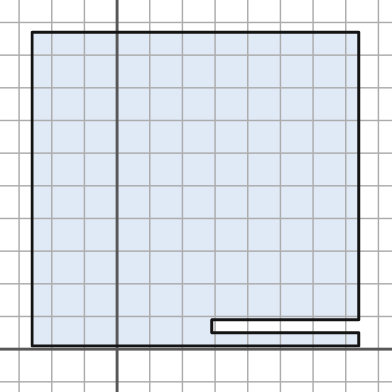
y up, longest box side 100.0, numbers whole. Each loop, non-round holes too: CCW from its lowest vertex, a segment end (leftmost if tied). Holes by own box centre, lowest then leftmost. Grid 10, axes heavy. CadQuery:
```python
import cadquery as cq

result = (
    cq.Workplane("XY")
    .moveTo(-26.0, 1.0)
    .lineTo(74.0, 1.0)
    .lineTo(74.0, 5.0)
    .lineTo(29.0, 5.0)
    .lineTo(29.0, 9.0)
    .lineTo(74.0, 9.0)
    .lineTo(74.0, 97.0)
    .lineTo(-26.0, 97.0)
    .close()
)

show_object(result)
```